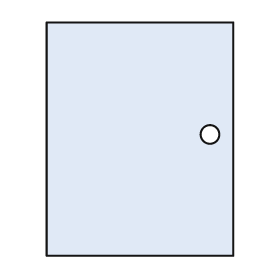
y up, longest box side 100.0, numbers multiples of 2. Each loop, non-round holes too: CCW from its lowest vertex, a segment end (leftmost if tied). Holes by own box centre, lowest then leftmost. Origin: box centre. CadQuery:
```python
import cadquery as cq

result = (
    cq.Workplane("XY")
    .moveTo(-40.0, -50.0)
    .lineTo(40.0, -50.0)
    .lineTo(40.0, 50.0)
    .lineTo(-40.0, 50.0)
    .close()
    .moveTo(30.0, 2.0)
    .circle(4.0)
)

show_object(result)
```